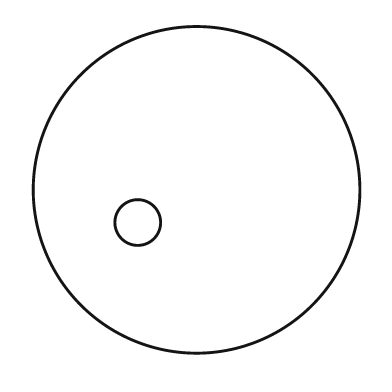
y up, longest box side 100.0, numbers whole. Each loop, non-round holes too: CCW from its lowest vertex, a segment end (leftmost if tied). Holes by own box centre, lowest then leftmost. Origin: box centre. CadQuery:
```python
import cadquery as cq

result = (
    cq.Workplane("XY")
    .moveTo(0.0, 0.0)
    .circle(50.0)
    .moveTo(-18.0, -10.0)
    .circle(7.0)
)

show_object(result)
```